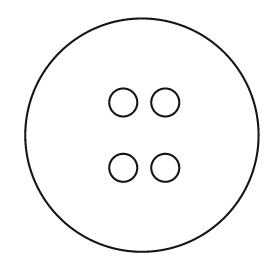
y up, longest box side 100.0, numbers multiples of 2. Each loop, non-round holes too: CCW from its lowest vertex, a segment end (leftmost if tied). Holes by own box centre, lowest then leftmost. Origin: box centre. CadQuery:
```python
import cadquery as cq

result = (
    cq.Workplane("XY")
    .moveTo(0.0, 0.0)
    .circle(50.0)
    .moveTo(-8.0, -14.0)
    .circle(6.0)
    .moveTo(10.0, -14.0)
    .circle(6.0)
    .moveTo(-8.0, 14.0)
    .circle(6.0)
    .moveTo(10.0, 14.0)
    .circle(6.0)
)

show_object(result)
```